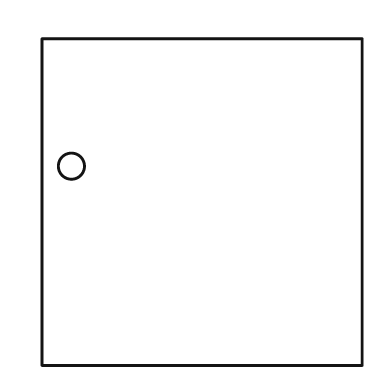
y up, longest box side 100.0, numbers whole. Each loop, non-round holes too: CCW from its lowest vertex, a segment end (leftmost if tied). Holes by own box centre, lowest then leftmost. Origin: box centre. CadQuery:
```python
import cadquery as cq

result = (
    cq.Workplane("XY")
    .moveTo(-49.0, -50.0)
    .lineTo(49.0, -50.0)
    .lineTo(49.0, 50.0)
    .lineTo(-49.0, 50.0)
    .close()
    .moveTo(-40.0, 11.0)
    .circle(4.0)
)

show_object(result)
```